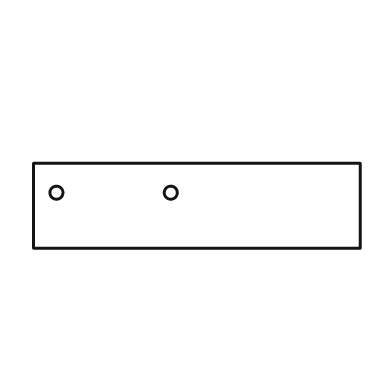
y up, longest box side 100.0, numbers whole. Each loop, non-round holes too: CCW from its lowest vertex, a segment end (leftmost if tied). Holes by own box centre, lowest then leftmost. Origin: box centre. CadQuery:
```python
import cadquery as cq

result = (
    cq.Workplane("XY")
    .moveTo(-50.0, -13.0)
    .lineTo(50.0, -13.0)
    .lineTo(50.0, 13.0)
    .lineTo(-50.0, 13.0)
    .close()
    .moveTo(-43.0, 4.0)
    .circle(2.0)
    .moveTo(-8.0, 4.0)
    .circle(2.0)
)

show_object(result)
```